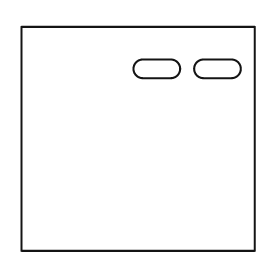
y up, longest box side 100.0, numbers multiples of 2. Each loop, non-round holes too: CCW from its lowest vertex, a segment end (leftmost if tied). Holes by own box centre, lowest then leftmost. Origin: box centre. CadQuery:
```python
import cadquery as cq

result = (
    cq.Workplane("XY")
    .moveTo(-50.0, -48.0)
    .lineTo(50.0, -48.0)
    .lineTo(50.0, 48.0)
    .lineTo(-50.0, 48.0)
    .close()
    .moveTo(2.0, 26.0)
    .lineTo(14.0, 26.0)
    .threePointArc((18.0, 30.0), (14.0, 34.0))
    .lineTo(2.0, 34.0)
    .threePointArc((-2.0, 30.0), (2.0, 26.0))
    .close()
    .moveTo(28.0, 26.0)
    .lineTo(40.0, 26.0)
    .threePointArc((44.0, 30.0), (40.0, 34.0))
    .lineTo(28.0, 34.0)
    .threePointArc((24.0, 30.0), (28.0, 26.0))
    .close()
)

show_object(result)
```